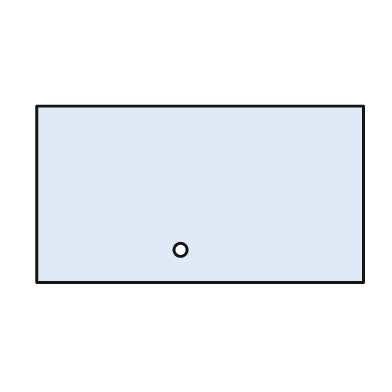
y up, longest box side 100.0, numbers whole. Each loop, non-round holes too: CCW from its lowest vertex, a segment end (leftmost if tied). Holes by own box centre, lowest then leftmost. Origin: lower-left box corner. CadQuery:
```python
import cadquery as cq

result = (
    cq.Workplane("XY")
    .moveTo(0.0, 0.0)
    .lineTo(100.0, 0.0)
    .lineTo(100.0, 54.0)
    .lineTo(0.0, 54.0)
    .close()
    .moveTo(44.0, 10.0)
    .circle(2.0)
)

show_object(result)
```